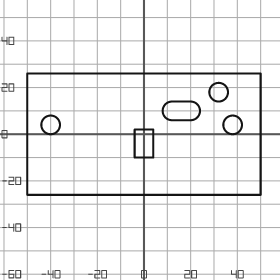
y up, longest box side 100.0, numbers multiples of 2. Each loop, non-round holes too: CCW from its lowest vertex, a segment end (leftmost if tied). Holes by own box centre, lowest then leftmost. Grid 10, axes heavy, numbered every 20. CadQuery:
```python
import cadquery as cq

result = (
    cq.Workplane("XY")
    .moveTo(-50.0, -26.0)
    .lineTo(50.0, -26.0)
    .lineTo(50.0, 26.0)
    .lineTo(-50.0, 26.0)
    .close()
    .moveTo(-4.0, -10.0)
    .lineTo(4.0, -10.0)
    .lineTo(4.0, 2.0)
    .lineTo(-4.0, 2.0)
    .close()
    .moveTo(-40.0, 4.0)
    .circle(4.0)
    .moveTo(38.0, 4.0)
    .circle(4.0)
    .moveTo(12.0, 6.0)
    .lineTo(20.0, 6.0)
    .threePointArc((24.0, 10.0), (20.0, 14.0))
    .lineTo(12.0, 14.0)
    .threePointArc((8.0, 10.0), (12.0, 6.0))
    .close()
    .moveTo(32.0, 18.0)
    .circle(4.0)
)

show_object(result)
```